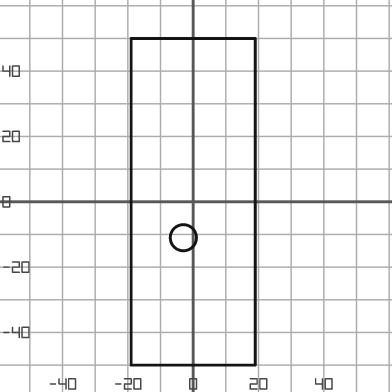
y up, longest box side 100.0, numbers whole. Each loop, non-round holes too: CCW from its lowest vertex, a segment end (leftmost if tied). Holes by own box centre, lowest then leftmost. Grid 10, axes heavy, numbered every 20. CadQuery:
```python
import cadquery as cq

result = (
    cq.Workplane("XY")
    .moveTo(-19.0, -50.0)
    .lineTo(19.0, -50.0)
    .lineTo(19.0, 50.0)
    .lineTo(-19.0, 50.0)
    .close()
    .moveTo(-3.0, -11.0)
    .circle(4.0)
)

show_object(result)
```